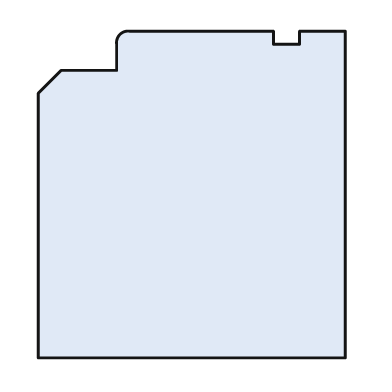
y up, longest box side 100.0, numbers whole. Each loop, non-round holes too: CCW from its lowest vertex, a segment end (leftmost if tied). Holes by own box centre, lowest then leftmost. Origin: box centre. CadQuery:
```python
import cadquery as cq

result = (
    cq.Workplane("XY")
    .moveTo(-47.0, -50.0)
    .lineTo(47.0, -50.0)
    .lineTo(47.0, 50.0)
    .lineTo(33.0, 50.0)
    .lineTo(33.0, 46.0)
    .lineTo(25.0, 46.0)
    .lineTo(25.0, 50.0)
    .lineTo(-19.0, 50.0)
    .threePointArc((-22.0, 49.0), (-23.0, 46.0))
    .lineTo(-23.0, 38.0)
    .lineTo(-40.0, 38.0)
    .lineTo(-47.0, 31.0)
    .close()
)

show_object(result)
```